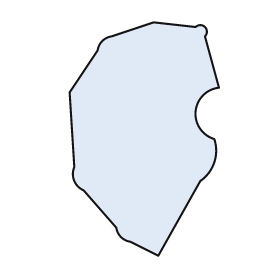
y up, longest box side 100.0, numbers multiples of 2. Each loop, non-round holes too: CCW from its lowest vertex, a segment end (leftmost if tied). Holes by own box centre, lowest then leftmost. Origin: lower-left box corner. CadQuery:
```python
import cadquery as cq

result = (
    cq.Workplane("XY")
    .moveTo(38.0, 0.0)
    .lineTo(56.0, 32.0)
    .threePointArc((62.0, 40.0), (62.0, 50.0))
    .threePointArc((54.0, 62.0), (64.0, 72.0))
    .lineTo(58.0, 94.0)
    .threePointArc((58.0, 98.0), (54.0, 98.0))
    .lineTo(36.0, 100.0)
    .lineTo(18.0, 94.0)
    .threePointArc((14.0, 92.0), (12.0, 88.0))
    .lineTo(0.0, 70.0)
    .lineTo(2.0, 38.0)
    .threePointArc((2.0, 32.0), (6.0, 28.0))
    .lineTo(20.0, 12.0)
    .threePointArc((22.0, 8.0), (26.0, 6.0))
    .close()
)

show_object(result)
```